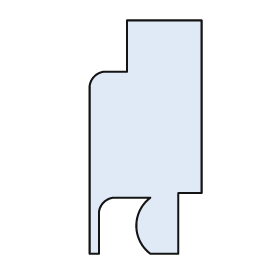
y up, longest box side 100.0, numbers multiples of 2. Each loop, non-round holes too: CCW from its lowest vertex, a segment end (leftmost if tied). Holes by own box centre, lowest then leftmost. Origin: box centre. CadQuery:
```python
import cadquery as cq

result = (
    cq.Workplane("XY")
    .moveTo(-24.0, -50.0)
    .lineTo(-20.0, -50.0)
    .lineTo(-20.0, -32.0)
    .threePointArc((-18.0, -28.0), (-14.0, -26.0))
    .lineTo(2.0, -26.0)
    .threePointArc((-4.0, -38.0), (2.0, -50.0))
    .lineTo(14.0, -50.0)
    .lineTo(14.0, -24.0)
    .lineTo(24.0, -24.0)
    .lineTo(24.0, 50.0)
    .lineTo(-8.0, 50.0)
    .lineTo(-8.0, 28.0)
    .lineTo(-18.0, 28.0)
    .threePointArc((-22.0, 26.0), (-24.0, 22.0))
    .close()
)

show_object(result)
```